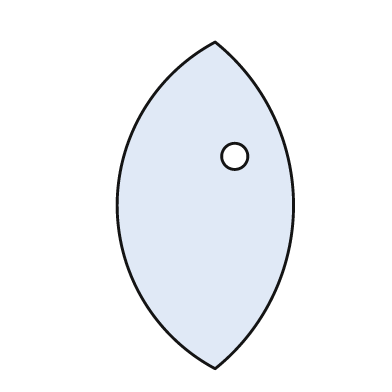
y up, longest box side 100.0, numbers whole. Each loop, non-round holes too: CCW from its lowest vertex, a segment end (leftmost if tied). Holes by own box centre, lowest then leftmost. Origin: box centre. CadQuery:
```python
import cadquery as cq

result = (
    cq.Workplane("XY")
    .moveTo(3.0, -50.0)
    .threePointArc((27.0, 0.0), (3.0, 50.0))
    .threePointArc((-27.0, 0.0), (3.0, -50.0))
    .close()
    .moveTo(9.0, 15.0)
    .circle(4.0)
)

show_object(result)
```